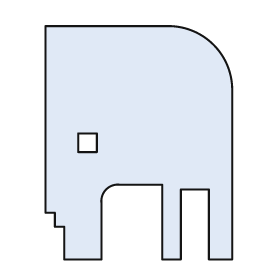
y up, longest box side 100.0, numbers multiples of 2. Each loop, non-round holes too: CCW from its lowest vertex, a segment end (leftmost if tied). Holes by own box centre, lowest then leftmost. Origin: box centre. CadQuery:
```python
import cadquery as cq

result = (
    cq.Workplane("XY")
    .moveTo(-32.0, -50.0)
    .lineTo(-16.0, -50.0)
    .lineTo(-16.0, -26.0)
    .threePointArc((-14.0, -20.0), (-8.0, -18.0))
    .lineTo(10.0, -18.0)
    .lineTo(10.0, -50.0)
    .lineTo(18.0, -50.0)
    .lineTo(18.0, -20.0)
    .lineTo(30.0, -20.0)
    .lineTo(30.0, -50.0)
    .lineTo(40.0, -50.0)
    .lineTo(40.0, 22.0)
    .threePointArc((32.0, 42.0), (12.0, 50.0))
    .lineTo(-40.0, 50.0)
    .lineTo(-40.0, -30.0)
    .lineTo(-36.0, -30.0)
    .lineTo(-36.0, -36.0)
    .lineTo(-32.0, -36.0)
    .close()
    .moveTo(-26.0, -4.0)
    .lineTo(-18.0, -4.0)
    .lineTo(-18.0, 4.0)
    .lineTo(-26.0, 4.0)
    .close()
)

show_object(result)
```